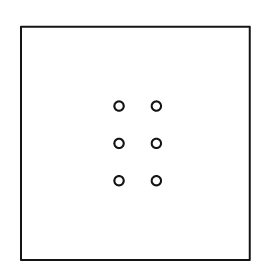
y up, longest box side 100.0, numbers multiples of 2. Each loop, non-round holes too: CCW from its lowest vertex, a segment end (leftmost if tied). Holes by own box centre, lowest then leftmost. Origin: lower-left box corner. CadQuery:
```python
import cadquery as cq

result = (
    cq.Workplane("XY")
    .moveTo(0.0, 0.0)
    .lineTo(98.0, 0.0)
    .lineTo(98.0, 100.0)
    .lineTo(0.0, 100.0)
    .close()
    .moveTo(42.0, 34.0)
    .circle(2.0)
    .moveTo(58.0, 34.0)
    .circle(2.0)
    .moveTo(42.0, 50.0)
    .circle(2.0)
    .moveTo(58.0, 50.0)
    .circle(2.0)
    .moveTo(42.0, 66.0)
    .circle(2.0)
    .moveTo(58.0, 66.0)
    .circle(2.0)
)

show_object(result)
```